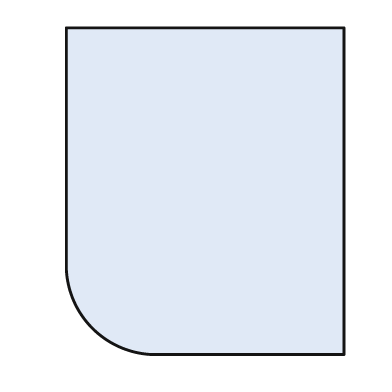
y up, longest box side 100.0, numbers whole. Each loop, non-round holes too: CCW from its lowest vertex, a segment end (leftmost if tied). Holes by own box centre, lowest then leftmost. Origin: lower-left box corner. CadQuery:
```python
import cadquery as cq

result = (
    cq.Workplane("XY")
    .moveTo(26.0, 0.0)
    .lineTo(85.0, 0.0)
    .lineTo(85.0, 100.0)
    .lineTo(0.0, 100.0)
    .lineTo(0.0, 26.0)
    .threePointArc((8.0, 8.0), (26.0, 0.0))
    .close()
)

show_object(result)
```